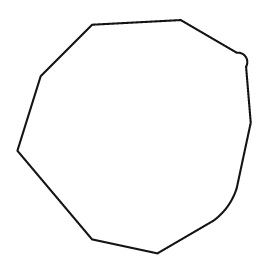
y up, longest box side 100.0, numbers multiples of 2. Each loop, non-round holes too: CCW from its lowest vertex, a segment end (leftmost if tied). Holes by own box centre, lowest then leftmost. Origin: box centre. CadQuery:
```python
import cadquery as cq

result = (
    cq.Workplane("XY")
    .moveTo(10.0, -50.0)
    .lineTo(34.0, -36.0)
    .threePointArc((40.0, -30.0), (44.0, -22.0))
    .lineTo(50.0, 6.0)
    .lineTo(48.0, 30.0)
    .threePointArc((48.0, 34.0), (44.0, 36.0))
    .lineTo(20.0, 50.0)
    .lineTo(-18.0, 48.0)
    .lineTo(-40.0, 26.0)
    .lineTo(-50.0, -6.0)
    .lineTo(-18.0, -44.0)
    .close()
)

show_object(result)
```